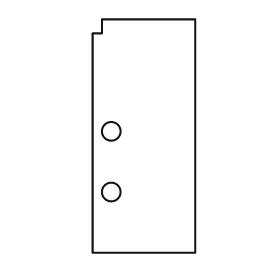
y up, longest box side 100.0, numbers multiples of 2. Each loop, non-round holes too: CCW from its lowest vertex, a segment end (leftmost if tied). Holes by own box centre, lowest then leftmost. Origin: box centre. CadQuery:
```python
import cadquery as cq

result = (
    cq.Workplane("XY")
    .moveTo(-22.0, -50.0)
    .lineTo(22.0, -50.0)
    .lineTo(22.0, 50.0)
    .lineTo(-18.0, 50.0)
    .lineTo(-18.0, 44.0)
    .lineTo(-22.0, 44.0)
    .close()
    .moveTo(-14.0, -24.0)
    .circle(4.0)
    .moveTo(-14.0, 2.0)
    .circle(4.0)
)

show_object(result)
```